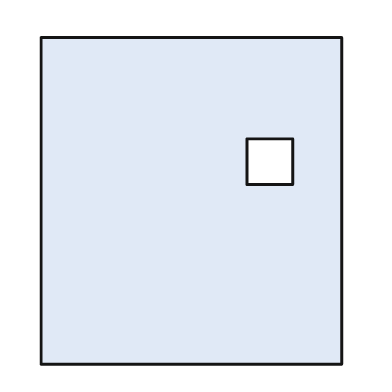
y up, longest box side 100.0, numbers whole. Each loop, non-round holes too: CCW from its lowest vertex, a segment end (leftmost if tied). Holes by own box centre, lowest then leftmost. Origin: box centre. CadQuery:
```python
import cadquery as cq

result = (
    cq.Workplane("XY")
    .moveTo(-46.0, -50.0)
    .lineTo(46.0, -50.0)
    .lineTo(46.0, 50.0)
    .lineTo(-46.0, 50.0)
    .close()
    .moveTo(17.0, 5.0)
    .lineTo(31.0, 5.0)
    .lineTo(31.0, 19.0)
    .lineTo(17.0, 19.0)
    .close()
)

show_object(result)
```